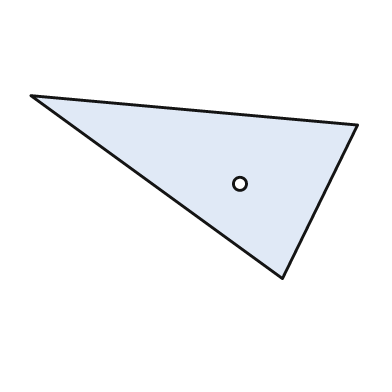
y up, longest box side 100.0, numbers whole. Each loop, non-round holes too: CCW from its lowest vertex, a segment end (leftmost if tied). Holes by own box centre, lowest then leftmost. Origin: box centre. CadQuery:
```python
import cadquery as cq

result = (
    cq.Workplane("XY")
    .moveTo(27.0, -28.0)
    .lineTo(50.0, 19.0)
    .lineTo(-50.0, 28.0)
    .close()
    .moveTo(14.0, 1.0)
    .circle(2.0)
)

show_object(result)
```